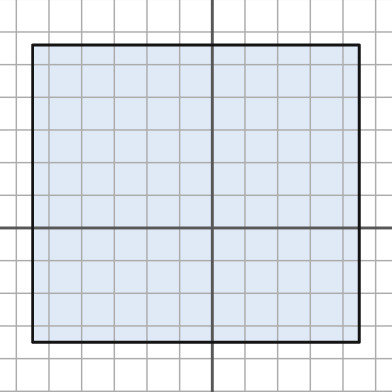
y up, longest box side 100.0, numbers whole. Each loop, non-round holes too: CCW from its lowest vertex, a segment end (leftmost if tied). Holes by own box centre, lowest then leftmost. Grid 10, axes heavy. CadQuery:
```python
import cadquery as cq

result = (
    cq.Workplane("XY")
    .moveTo(-55.0, -35.0)
    .lineTo(45.0, -35.0)
    .lineTo(45.0, 56.0)
    .lineTo(-55.0, 56.0)
    .close()
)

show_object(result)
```